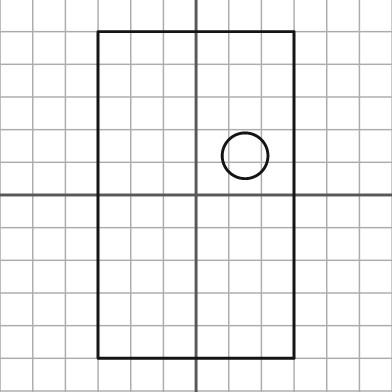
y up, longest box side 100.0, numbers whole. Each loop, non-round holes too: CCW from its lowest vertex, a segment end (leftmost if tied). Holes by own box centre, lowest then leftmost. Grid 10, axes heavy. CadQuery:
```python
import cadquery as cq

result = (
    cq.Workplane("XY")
    .moveTo(-30.0, -50.0)
    .lineTo(30.0, -50.0)
    .lineTo(30.0, 50.0)
    .lineTo(-30.0, 50.0)
    .close()
    .moveTo(15.0, 12.0)
    .circle(7.0)
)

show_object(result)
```